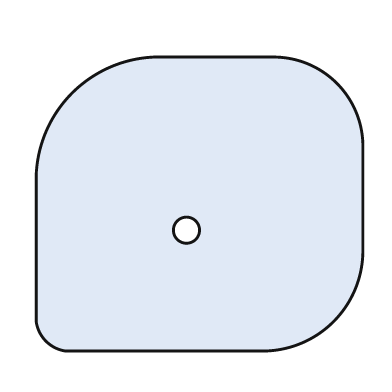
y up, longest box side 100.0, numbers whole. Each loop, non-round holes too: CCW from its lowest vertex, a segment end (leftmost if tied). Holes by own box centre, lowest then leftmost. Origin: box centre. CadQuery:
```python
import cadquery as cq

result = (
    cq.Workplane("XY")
    .moveTo(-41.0, -45.0)
    .lineTo(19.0, -45.0)
    .threePointArc((41.0, -36.0), (50.0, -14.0))
    .lineTo(50.0, 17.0)
    .threePointArc((42.0, 37.0), (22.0, 45.0))
    .lineTo(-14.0, 45.0)
    .threePointArc((-39.0, 34.0), (-50.0, 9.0))
    .lineTo(-50.0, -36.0)
    .threePointArc((-47.0, -42.0), (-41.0, -45.0))
    .close()
    .moveTo(-4.0, -8.0)
    .circle(4.0)
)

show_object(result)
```